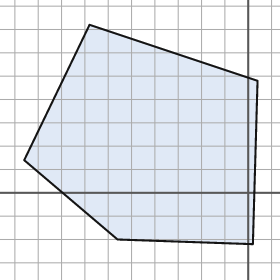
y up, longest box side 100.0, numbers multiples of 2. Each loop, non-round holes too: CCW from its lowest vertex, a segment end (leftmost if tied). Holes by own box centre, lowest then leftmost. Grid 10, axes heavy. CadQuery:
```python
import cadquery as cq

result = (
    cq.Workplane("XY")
    .moveTo(2.0, -22.0)
    .lineTo(4.0, 48.0)
    .lineTo(-68.0, 72.0)
    .lineTo(-96.0, 14.0)
    .lineTo(-56.0, -20.0)
    .close()
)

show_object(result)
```